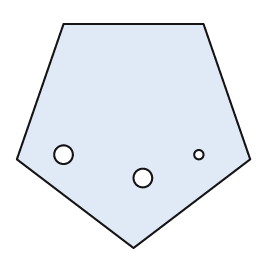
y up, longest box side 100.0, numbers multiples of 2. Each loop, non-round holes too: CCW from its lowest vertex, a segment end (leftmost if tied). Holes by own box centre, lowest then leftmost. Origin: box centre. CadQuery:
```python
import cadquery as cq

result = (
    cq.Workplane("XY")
    .moveTo(0.0, -48.0)
    .lineTo(50.0, -10.0)
    .lineTo(30.0, 48.0)
    .lineTo(-30.0, 48.0)
    .lineTo(-50.0, -10.0)
    .close()
    .moveTo(4.0, -18.0)
    .circle(4.0)
    .moveTo(-30.0, -8.0)
    .circle(4.0)
    .moveTo(28.0, -8.0)
    .circle(2.0)
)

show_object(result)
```